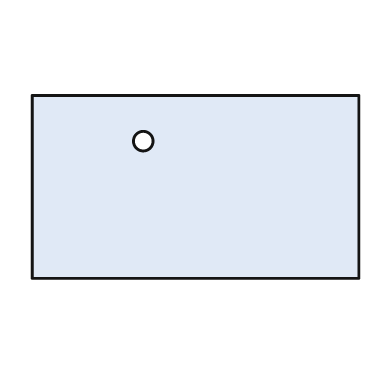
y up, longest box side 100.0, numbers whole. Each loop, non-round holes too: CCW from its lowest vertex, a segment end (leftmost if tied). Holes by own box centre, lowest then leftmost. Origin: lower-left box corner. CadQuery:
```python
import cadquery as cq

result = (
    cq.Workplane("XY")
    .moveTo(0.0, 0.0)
    .lineTo(100.0, 0.0)
    .lineTo(100.0, 56.0)
    .lineTo(0.0, 56.0)
    .close()
    .moveTo(34.0, 42.0)
    .circle(3.0)
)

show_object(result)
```